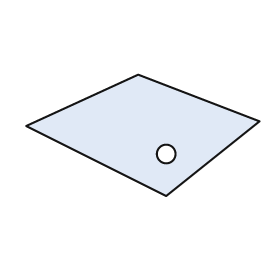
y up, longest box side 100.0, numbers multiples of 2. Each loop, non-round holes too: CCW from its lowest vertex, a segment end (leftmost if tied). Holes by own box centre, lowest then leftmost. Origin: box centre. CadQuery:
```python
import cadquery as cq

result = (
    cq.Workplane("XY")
    .moveTo(10.0, -26.0)
    .lineTo(50.0, 6.0)
    .lineTo(-2.0, 26.0)
    .lineTo(-50.0, 4.0)
    .close()
    .moveTo(10.0, -8.0)
    .circle(4.0)
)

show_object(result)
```